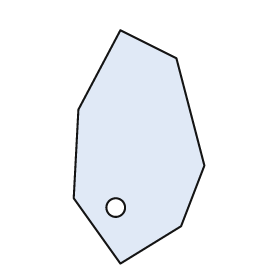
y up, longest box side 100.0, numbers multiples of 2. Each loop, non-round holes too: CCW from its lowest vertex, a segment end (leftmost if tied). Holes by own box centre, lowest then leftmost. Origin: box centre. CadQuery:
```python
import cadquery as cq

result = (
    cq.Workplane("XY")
    .moveTo(-8.0, -50.0)
    .lineTo(18.0, -34.0)
    .lineTo(28.0, -8.0)
    .lineTo(16.0, 38.0)
    .lineTo(-8.0, 50.0)
    .lineTo(-26.0, 16.0)
    .lineTo(-28.0, -22.0)
    .close()
    .moveTo(-10.0, -26.0)
    .circle(4.0)
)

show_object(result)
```